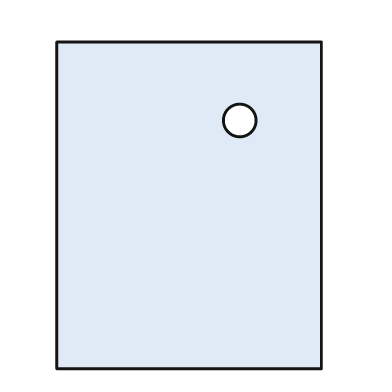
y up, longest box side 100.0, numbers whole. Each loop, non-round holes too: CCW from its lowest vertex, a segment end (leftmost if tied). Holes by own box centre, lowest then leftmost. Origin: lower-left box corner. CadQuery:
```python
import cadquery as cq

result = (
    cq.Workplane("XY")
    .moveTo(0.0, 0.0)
    .lineTo(81.0, 0.0)
    .lineTo(81.0, 100.0)
    .lineTo(0.0, 100.0)
    .close()
    .moveTo(56.0, 76.0)
    .circle(5.0)
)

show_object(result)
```